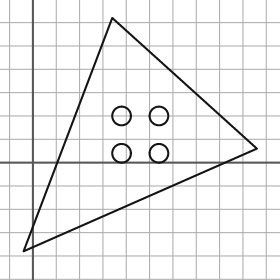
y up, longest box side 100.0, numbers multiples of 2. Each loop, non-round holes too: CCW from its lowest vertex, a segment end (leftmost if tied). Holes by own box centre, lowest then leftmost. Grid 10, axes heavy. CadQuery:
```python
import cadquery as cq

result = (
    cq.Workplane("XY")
    .moveTo(-4.0, -38.0)
    .lineTo(96.0, 6.0)
    .lineTo(34.0, 62.0)
    .close()
    .moveTo(38.0, 4.0)
    .circle(4.0)
    .moveTo(54.0, 4.0)
    .circle(4.0)
    .moveTo(38.0, 20.0)
    .circle(4.0)
    .moveTo(54.0, 20.0)
    .circle(4.0)
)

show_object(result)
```